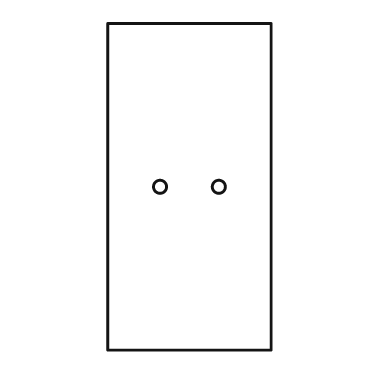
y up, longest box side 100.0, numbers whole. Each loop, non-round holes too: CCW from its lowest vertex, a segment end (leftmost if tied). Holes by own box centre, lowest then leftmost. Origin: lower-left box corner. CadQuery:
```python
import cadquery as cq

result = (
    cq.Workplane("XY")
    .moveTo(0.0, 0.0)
    .lineTo(50.0, 0.0)
    .lineTo(50.0, 100.0)
    .lineTo(0.0, 100.0)
    .close()
    .moveTo(16.0, 50.0)
    .circle(2.0)
    .moveTo(34.0, 50.0)
    .circle(2.0)
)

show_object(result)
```